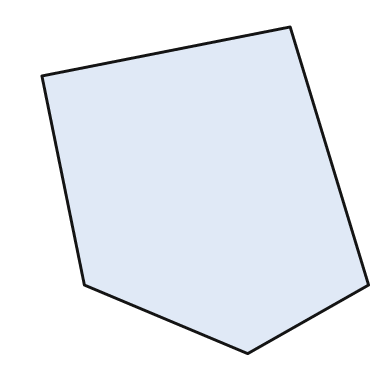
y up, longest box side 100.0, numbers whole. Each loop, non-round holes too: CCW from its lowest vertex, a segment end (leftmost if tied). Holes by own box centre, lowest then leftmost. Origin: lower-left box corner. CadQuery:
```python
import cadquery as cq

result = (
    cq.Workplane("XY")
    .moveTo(63.0, 0.0)
    .lineTo(100.0, 21.0)
    .lineTo(76.0, 100.0)
    .lineTo(0.0, 85.0)
    .lineTo(13.0, 21.0)
    .close()
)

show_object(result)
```